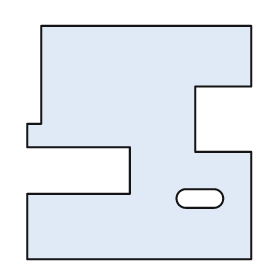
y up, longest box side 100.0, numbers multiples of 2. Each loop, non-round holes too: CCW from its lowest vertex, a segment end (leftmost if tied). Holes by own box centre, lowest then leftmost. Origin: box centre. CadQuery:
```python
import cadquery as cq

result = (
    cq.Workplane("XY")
    .moveTo(-48.0, -50.0)
    .lineTo(48.0, -50.0)
    .lineTo(48.0, -4.0)
    .lineTo(24.0, -4.0)
    .lineTo(24.0, 24.0)
    .lineTo(48.0, 24.0)
    .lineTo(48.0, 50.0)
    .lineTo(-42.0, 50.0)
    .lineTo(-42.0, 8.0)
    .lineTo(-48.0, 8.0)
    .lineTo(-48.0, -2.0)
    .lineTo(-4.0, -2.0)
    .lineTo(-4.0, -22.0)
    .lineTo(-48.0, -22.0)
    .close()
    .moveTo(20.0, -28.0)
    .lineTo(32.0, -28.0)
    .threePointArc((36.0, -24.0), (32.0, -20.0))
    .lineTo(20.0, -20.0)
    .threePointArc((16.0, -24.0), (20.0, -28.0))
    .close()
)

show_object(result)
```